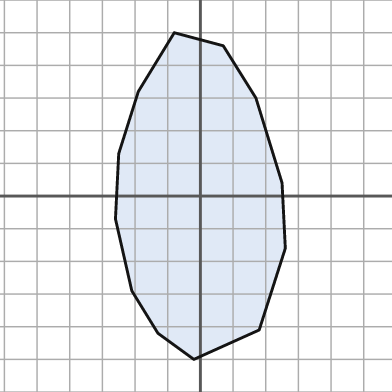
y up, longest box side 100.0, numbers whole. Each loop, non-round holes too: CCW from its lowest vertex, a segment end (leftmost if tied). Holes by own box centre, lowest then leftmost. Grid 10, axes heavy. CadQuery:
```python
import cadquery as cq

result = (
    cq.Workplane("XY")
    .moveTo(-2.0, -50.0)
    .lineTo(18.0, -41.0)
    .lineTo(26.0, -16.0)
    .lineTo(25.0, 4.0)
    .lineTo(17.0, 30.0)
    .lineTo(7.0, 46.0)
    .lineTo(-8.0, 50.0)
    .lineTo(-19.0, 32.0)
    .lineTo(-25.0, 13.0)
    .lineTo(-26.0, -7.0)
    .lineTo(-21.0, -29.0)
    .lineTo(-13.0, -42.0)
    .close()
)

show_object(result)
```